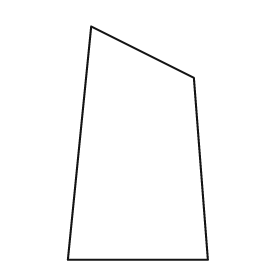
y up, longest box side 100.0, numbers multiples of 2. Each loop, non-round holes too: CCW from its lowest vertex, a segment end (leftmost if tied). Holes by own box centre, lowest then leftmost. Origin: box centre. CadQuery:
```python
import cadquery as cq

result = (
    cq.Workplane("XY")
    .moveTo(-30.0, -50.0)
    .lineTo(30.0, -50.0)
    .lineTo(24.0, 28.0)
    .lineTo(-20.0, 50.0)
    .close()
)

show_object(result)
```